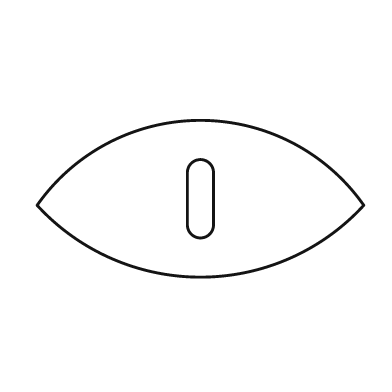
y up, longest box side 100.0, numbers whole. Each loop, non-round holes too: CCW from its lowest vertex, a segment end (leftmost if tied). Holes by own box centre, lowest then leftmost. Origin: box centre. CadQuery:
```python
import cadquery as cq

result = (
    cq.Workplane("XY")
    .moveTo(-50.0, -2.0)
    .threePointArc((0.0, -24.0), (50.0, -2.0))
    .threePointArc((0.0, 24.0), (-50.0, -2.0))
    .close()
    .moveTo(-4.0, -8.0)
    .threePointArc((0.0, -12.0), (4.0, -8.0))
    .lineTo(4.0, 8.0)
    .threePointArc((0.0, 12.0), (-4.0, 8.0))
    .close()
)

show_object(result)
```